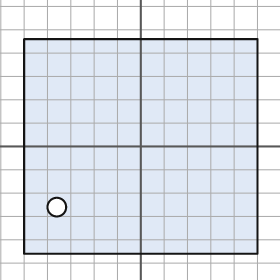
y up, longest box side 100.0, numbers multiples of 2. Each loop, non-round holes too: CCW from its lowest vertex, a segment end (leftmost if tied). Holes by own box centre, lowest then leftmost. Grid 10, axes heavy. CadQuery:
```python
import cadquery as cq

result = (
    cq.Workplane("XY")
    .moveTo(-50.0, -46.0)
    .lineTo(50.0, -46.0)
    .lineTo(50.0, 46.0)
    .lineTo(-50.0, 46.0)
    .close()
    .moveTo(-36.0, -26.0)
    .circle(4.0)
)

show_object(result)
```